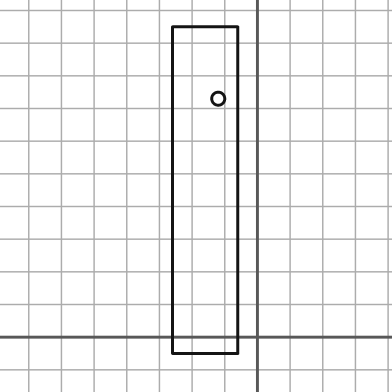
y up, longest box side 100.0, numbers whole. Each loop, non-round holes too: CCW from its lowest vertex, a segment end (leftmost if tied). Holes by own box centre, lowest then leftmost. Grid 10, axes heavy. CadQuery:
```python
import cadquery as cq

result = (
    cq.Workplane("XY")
    .moveTo(-26.0, -5.0)
    .lineTo(-6.0, -5.0)
    .lineTo(-6.0, 95.0)
    .lineTo(-26.0, 95.0)
    .close()
    .moveTo(-12.0, 73.0)
    .circle(2.0)
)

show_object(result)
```